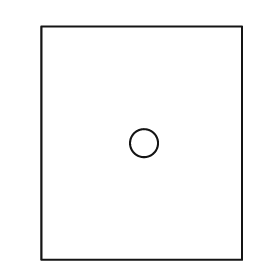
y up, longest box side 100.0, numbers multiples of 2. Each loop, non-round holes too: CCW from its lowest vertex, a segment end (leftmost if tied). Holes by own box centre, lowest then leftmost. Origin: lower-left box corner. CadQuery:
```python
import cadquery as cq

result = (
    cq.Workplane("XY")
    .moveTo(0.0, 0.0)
    .lineTo(86.0, 0.0)
    .lineTo(86.0, 100.0)
    .lineTo(0.0, 100.0)
    .close()
    .moveTo(44.0, 50.0)
    .circle(6.0)
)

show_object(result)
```